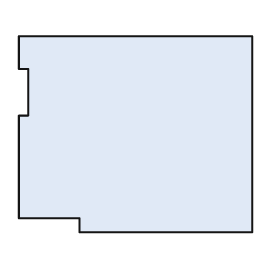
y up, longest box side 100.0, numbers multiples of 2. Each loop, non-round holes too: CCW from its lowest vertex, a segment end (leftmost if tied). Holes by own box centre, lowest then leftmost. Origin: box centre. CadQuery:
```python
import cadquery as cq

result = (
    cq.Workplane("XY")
    .moveTo(-24.0, -42.0)
    .lineTo(50.0, -42.0)
    .lineTo(50.0, 42.0)
    .lineTo(-50.0, 42.0)
    .lineTo(-50.0, 28.0)
    .lineTo(-46.0, 28.0)
    .lineTo(-46.0, 8.0)
    .lineTo(-50.0, 8.0)
    .lineTo(-50.0, -36.0)
    .lineTo(-24.0, -36.0)
    .close()
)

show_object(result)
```